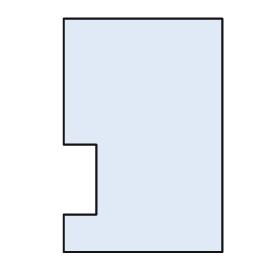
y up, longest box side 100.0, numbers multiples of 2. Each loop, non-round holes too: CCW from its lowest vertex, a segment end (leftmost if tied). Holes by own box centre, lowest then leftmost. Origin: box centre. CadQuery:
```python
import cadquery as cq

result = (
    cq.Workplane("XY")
    .moveTo(-34.0, -50.0)
    .lineTo(34.0, -50.0)
    .lineTo(34.0, 50.0)
    .lineTo(-34.0, 50.0)
    .lineTo(-34.0, -4.0)
    .lineTo(-20.0, -4.0)
    .lineTo(-20.0, -34.0)
    .lineTo(-34.0, -34.0)
    .close()
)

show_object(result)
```